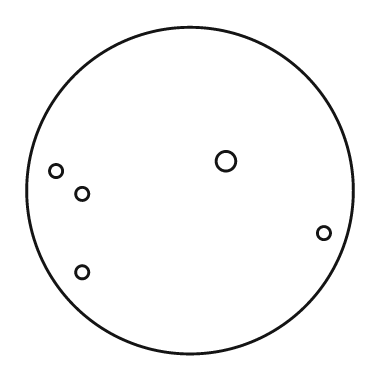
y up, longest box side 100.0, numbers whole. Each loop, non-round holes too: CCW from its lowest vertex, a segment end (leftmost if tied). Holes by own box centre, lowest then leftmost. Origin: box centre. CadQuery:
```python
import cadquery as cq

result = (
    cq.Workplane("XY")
    .moveTo(0.0, 0.0)
    .circle(50.0)
    .moveTo(-33.0, -25.0)
    .circle(2.0)
    .moveTo(41.0, -13.0)
    .circle(2.0)
    .moveTo(-33.0, -1.0)
    .circle(2.0)
    .moveTo(-41.0, 6.0)
    .circle(2.0)
    .moveTo(11.0, 9.0)
    .circle(3.0)
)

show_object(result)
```